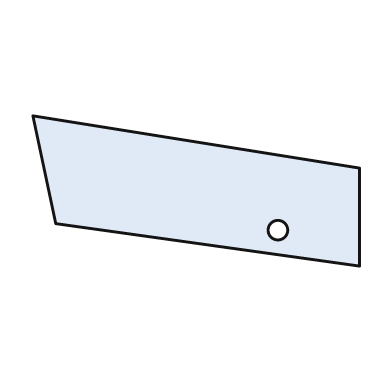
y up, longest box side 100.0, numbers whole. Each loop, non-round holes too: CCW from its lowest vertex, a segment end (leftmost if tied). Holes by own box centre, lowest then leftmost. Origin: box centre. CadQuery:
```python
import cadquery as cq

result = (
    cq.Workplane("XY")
    .moveTo(50.0, -23.0)
    .lineTo(50.0, 7.0)
    .lineTo(-50.0, 23.0)
    .lineTo(-43.0, -10.0)
    .close()
    .moveTo(25.0, -12.0)
    .circle(3.0)
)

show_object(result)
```